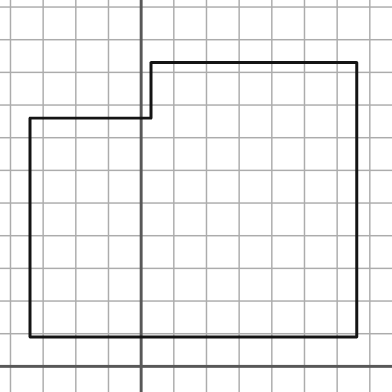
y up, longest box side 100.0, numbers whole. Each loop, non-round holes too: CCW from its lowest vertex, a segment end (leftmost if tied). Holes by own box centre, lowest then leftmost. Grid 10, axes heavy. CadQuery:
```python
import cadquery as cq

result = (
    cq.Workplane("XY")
    .moveTo(-34.0, 9.0)
    .lineTo(66.0, 9.0)
    .lineTo(66.0, 93.0)
    .lineTo(3.0, 93.0)
    .lineTo(3.0, 76.0)
    .lineTo(-34.0, 76.0)
    .close()
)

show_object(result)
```